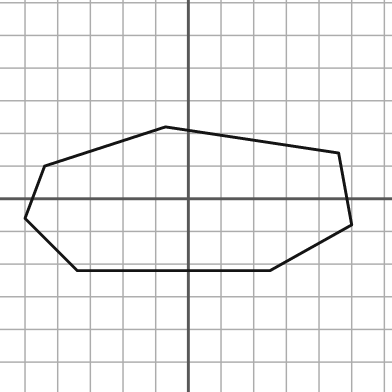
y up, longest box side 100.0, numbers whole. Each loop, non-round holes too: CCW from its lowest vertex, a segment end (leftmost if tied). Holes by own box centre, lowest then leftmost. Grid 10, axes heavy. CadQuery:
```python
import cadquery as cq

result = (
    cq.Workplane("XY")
    .moveTo(-34.0, -22.0)
    .lineTo(25.0, -22.0)
    .lineTo(50.0, -8.0)
    .lineTo(46.0, 14.0)
    .lineTo(-7.0, 22.0)
    .lineTo(-44.0, 10.0)
    .lineTo(-50.0, -6.0)
    .close()
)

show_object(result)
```